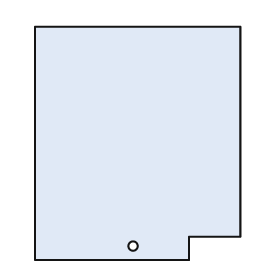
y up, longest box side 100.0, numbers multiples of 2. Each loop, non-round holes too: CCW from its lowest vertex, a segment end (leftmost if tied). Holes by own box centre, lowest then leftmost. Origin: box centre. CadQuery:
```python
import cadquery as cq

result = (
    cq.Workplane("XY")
    .moveTo(-44.0, -50.0)
    .lineTo(22.0, -50.0)
    .lineTo(22.0, -40.0)
    .lineTo(44.0, -40.0)
    .lineTo(44.0, 50.0)
    .lineTo(-44.0, 50.0)
    .close()
    .moveTo(-2.0, -44.0)
    .circle(2.0)
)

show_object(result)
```